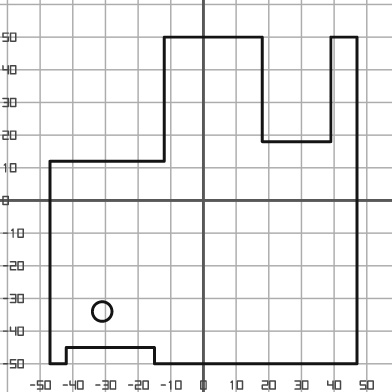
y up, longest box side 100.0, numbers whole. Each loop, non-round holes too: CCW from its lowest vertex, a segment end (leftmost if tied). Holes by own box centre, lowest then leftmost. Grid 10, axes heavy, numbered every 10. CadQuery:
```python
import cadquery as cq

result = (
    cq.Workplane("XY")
    .moveTo(-47.0, -50.0)
    .lineTo(-42.0, -50.0)
    .lineTo(-42.0, -45.0)
    .lineTo(-15.0, -45.0)
    .lineTo(-15.0, -50.0)
    .lineTo(47.0, -50.0)
    .lineTo(47.0, 50.0)
    .lineTo(39.0, 50.0)
    .lineTo(39.0, 18.0)
    .lineTo(18.0, 18.0)
    .lineTo(18.0, 50.0)
    .lineTo(-12.0, 50.0)
    .lineTo(-12.0, 12.0)
    .lineTo(-47.0, 12.0)
    .close()
    .moveTo(-31.0, -34.0)
    .circle(3.0)
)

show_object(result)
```